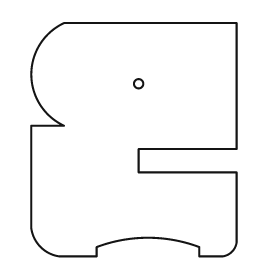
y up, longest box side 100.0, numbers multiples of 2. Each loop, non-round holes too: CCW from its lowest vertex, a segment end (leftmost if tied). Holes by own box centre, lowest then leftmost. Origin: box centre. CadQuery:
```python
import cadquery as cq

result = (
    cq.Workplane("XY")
    .moveTo(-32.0, -50.0)
    .lineTo(-16.0, -50.0)
    .lineTo(-16.0, -46.0)
    .threePointArc((6.0, -42.0), (28.0, -46.0))
    .lineTo(28.0, -50.0)
    .lineTo(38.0, -50.0)
    .threePointArc((42.0, -48.0), (44.0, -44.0))
    .lineTo(44.0, -14.0)
    .lineTo(2.0, -14.0)
    .lineTo(2.0, -4.0)
    .lineTo(44.0, -4.0)
    .lineTo(44.0, 50.0)
    .lineTo(-30.0, 50.0)
    .threePointArc((-44.0, 28.0), (-30.0, 6.0))
    .lineTo(-44.0, 6.0)
    .lineTo(-44.0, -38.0)
    .threePointArc((-40.0, -46.0), (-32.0, -50.0))
    .close()
    .moveTo(2.0, 24.0)
    .circle(2.0)
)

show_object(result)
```